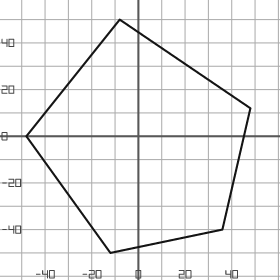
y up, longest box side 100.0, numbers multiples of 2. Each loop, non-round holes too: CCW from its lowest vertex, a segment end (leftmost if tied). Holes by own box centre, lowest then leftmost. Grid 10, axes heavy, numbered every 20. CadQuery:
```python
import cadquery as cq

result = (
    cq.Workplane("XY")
    .moveTo(-12.0, -50.0)
    .lineTo(36.0, -40.0)
    .lineTo(48.0, 12.0)
    .lineTo(-8.0, 50.0)
    .lineTo(-48.0, 0.0)
    .close()
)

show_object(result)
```